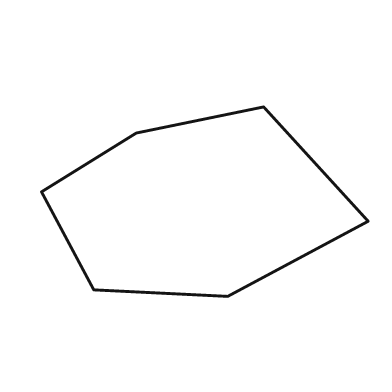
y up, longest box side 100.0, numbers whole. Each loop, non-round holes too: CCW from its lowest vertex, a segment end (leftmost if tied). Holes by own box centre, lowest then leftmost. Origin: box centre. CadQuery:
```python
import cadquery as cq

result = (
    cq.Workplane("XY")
    .moveTo(7.0, -29.0)
    .lineTo(50.0, -6.0)
    .lineTo(18.0, 29.0)
    .lineTo(-21.0, 21.0)
    .lineTo(-50.0, 3.0)
    .lineTo(-34.0, -27.0)
    .close()
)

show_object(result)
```